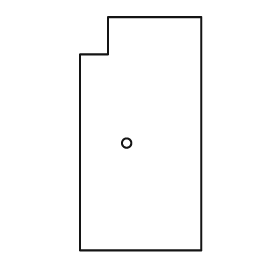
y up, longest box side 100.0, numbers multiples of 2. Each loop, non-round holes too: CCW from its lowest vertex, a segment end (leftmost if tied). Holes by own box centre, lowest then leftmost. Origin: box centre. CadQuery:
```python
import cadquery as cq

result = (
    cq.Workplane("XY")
    .moveTo(-26.0, -50.0)
    .lineTo(26.0, -50.0)
    .lineTo(26.0, 50.0)
    .lineTo(-14.0, 50.0)
    .lineTo(-14.0, 34.0)
    .lineTo(-26.0, 34.0)
    .close()
    .moveTo(-6.0, -4.0)
    .circle(2.0)
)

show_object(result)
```